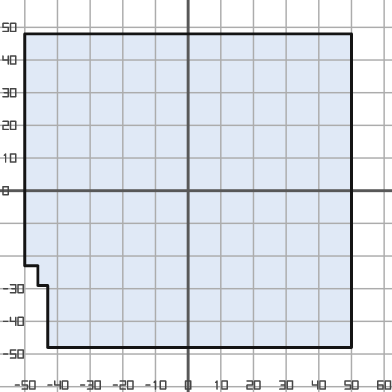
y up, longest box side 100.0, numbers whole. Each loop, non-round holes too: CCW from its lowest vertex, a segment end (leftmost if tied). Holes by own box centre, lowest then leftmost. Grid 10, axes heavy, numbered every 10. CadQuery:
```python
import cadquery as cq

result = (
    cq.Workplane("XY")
    .moveTo(-43.0, -48.0)
    .lineTo(50.0, -48.0)
    .lineTo(50.0, 48.0)
    .lineTo(-50.0, 48.0)
    .lineTo(-50.0, -23.0)
    .lineTo(-46.0, -23.0)
    .lineTo(-46.0, -29.0)
    .lineTo(-43.0, -29.0)
    .close()
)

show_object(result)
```